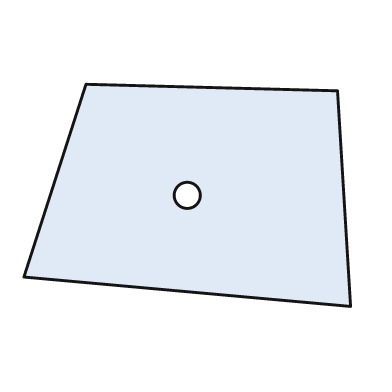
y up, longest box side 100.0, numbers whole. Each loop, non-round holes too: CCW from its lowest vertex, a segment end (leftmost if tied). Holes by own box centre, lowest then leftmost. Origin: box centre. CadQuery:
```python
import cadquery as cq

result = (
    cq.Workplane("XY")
    .moveTo(50.0, -34.0)
    .lineTo(46.0, 32.0)
    .lineTo(-31.0, 34.0)
    .lineTo(-50.0, -25.0)
    .close()
    .moveTo(0.0, 0.0)
    .circle(4.0)
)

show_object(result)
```